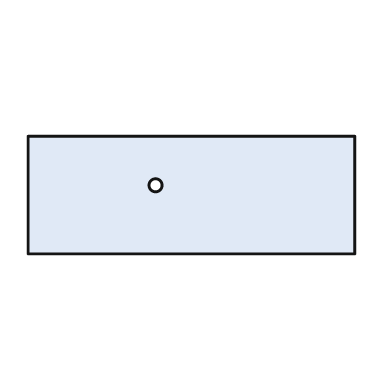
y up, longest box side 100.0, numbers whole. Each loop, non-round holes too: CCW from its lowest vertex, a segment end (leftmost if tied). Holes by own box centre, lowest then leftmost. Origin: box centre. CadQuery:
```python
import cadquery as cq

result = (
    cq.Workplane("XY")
    .moveTo(-50.0, -18.0)
    .lineTo(50.0, -18.0)
    .lineTo(50.0, 18.0)
    .lineTo(-50.0, 18.0)
    .close()
    .moveTo(-11.0, 3.0)
    .circle(2.0)
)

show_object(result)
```